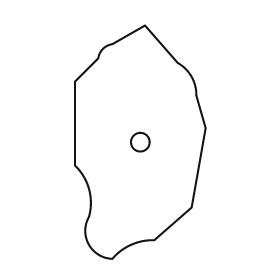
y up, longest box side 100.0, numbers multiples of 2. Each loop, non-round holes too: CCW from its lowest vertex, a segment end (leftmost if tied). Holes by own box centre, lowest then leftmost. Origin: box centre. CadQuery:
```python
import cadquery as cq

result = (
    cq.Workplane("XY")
    .moveTo(-12.0, -50.0)
    .threePointArc((-4.0, -44.0), (6.0, -42.0))
    .lineTo(22.0, -28.0)
    .lineTo(28.0, 6.0)
    .lineTo(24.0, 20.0)
    .threePointArc((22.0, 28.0), (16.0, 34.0))
    .lineTo(2.0, 50.0)
    .lineTo(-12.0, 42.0)
    .threePointArc((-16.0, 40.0), (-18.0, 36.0))
    .lineTo(-28.0, 26.0)
    .lineTo(-28.0, -10.0)
    .threePointArc((-22.0, -20.0), (-22.0, -32.0))
    .threePointArc((-22.0, -44.0), (-12.0, -50.0))
    .close()
    .moveTo(0.0, 0.0)
    .circle(4.0)
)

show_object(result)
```